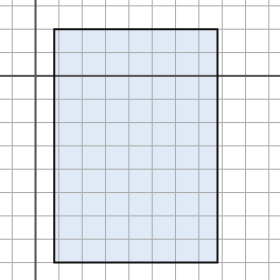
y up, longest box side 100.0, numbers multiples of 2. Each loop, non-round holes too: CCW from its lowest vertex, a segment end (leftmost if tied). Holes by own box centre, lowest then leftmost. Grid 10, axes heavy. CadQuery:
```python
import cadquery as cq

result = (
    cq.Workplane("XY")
    .moveTo(8.0, -80.0)
    .lineTo(78.0, -80.0)
    .lineTo(78.0, 20.0)
    .lineTo(8.0, 20.0)
    .close()
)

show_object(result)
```